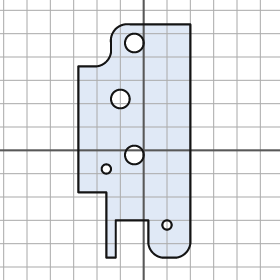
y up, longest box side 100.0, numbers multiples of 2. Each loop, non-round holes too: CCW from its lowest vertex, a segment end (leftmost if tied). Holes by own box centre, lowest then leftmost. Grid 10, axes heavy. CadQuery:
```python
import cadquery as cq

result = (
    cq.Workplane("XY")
    .moveTo(-16.0, -46.0)
    .lineTo(-12.0, -46.0)
    .lineTo(-12.0, -30.0)
    .lineTo(2.0, -30.0)
    .lineTo(2.0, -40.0)
    .threePointArc((4.0, -44.0), (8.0, -46.0))
    .lineTo(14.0, -46.0)
    .threePointArc((18.0, -44.0), (20.0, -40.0))
    .lineTo(20.0, 54.0)
    .lineTo(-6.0, 54.0)
    .threePointArc((-12.0, 52.0), (-14.0, 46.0))
    .lineTo(-14.0, 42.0)
    .threePointArc((-16.0, 38.0), (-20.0, 36.0))
    .lineTo(-28.0, 36.0)
    .lineTo(-28.0, -18.0)
    .lineTo(-16.0, -18.0)
    .close()
    .moveTo(10.0, -32.0)
    .circle(2.0)
    .moveTo(-16.0, -8.0)
    .circle(2.0)
    .moveTo(-4.0, -2.0)
    .circle(4.0)
    .moveTo(-10.0, 22.0)
    .circle(4.0)
    .moveTo(-4.0, 46.0)
    .circle(4.0)
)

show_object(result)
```